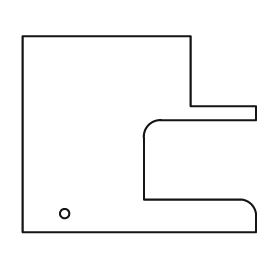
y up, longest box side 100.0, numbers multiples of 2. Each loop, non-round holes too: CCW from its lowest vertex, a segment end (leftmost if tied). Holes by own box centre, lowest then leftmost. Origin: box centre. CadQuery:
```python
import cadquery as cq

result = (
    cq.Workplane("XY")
    .moveTo(-50.0, -42.0)
    .lineTo(50.0, -42.0)
    .lineTo(50.0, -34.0)
    .threePointArc((48.0, -30.0), (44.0, -28.0))
    .lineTo(2.0, -28.0)
    .lineTo(2.0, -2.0)
    .threePointArc((4.0, 4.0), (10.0, 6.0))
    .lineTo(50.0, 6.0)
    .lineTo(50.0, 12.0)
    .lineTo(22.0, 12.0)
    .lineTo(22.0, 42.0)
    .lineTo(-50.0, 42.0)
    .close()
    .moveTo(-32.0, -34.0)
    .circle(2.0)
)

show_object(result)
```